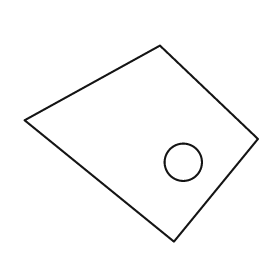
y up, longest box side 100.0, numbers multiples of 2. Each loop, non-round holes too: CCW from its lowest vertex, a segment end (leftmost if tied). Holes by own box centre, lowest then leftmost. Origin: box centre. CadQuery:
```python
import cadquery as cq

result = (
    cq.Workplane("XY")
    .moveTo(14.0, -42.0)
    .lineTo(50.0, 2.0)
    .lineTo(8.0, 42.0)
    .lineTo(-50.0, 10.0)
    .close()
    .moveTo(18.0, -8.0)
    .circle(8.0)
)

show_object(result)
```